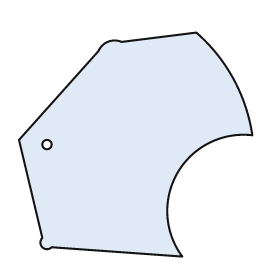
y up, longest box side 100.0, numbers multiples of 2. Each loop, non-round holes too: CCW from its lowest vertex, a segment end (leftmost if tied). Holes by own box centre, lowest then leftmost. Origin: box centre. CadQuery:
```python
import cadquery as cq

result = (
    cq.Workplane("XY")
    .moveTo(20.0, -48.0)
    .threePointArc((18.0, -12.0), (50.0, 4.0))
    .threePointArc((42.0, 28.0), (26.0, 48.0))
    .lineTo(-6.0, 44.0)
    .threePointArc((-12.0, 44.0), (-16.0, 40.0))
    .lineTo(-50.0, 2.0)
    .lineTo(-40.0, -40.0)
    .threePointArc((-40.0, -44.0), (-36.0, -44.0))
    .close()
    .moveTo(-38.0, 0.0)
    .circle(2.0)
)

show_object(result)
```